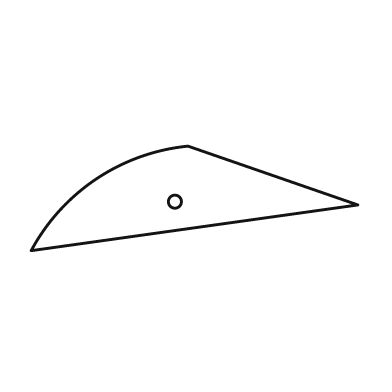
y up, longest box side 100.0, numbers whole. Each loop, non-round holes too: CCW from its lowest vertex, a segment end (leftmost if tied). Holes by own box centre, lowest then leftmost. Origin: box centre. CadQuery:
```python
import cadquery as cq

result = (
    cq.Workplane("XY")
    .moveTo(-50.0, -16.0)
    .lineTo(50.0, -2.0)
    .lineTo(-2.0, 16.0)
    .threePointArc((-30.0, 6.0), (-50.0, -16.0))
    .close()
    .moveTo(-6.0, -1.0)
    .circle(2.0)
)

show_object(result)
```